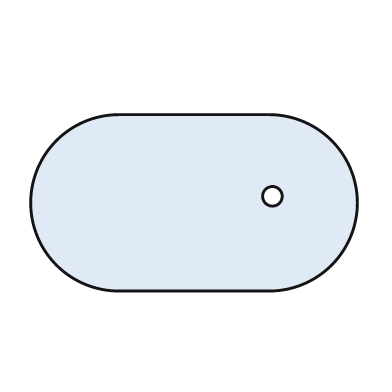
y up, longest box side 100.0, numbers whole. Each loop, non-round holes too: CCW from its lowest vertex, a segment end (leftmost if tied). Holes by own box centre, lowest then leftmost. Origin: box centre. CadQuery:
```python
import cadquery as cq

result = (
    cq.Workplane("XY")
    .moveTo(-23.0, -27.0)
    .lineTo(23.0, -27.0)
    .threePointArc((50.0, 0.0), (23.0, 27.0))
    .lineTo(-23.0, 27.0)
    .threePointArc((-50.0, 0.0), (-23.0, -27.0))
    .close()
    .moveTo(24.0, 2.0)
    .circle(3.0)
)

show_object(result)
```